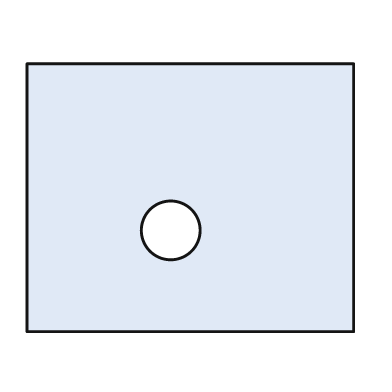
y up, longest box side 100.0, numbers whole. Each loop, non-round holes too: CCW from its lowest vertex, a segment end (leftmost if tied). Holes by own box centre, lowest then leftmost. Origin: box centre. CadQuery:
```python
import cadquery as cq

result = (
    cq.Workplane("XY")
    .moveTo(-50.0, -41.0)
    .lineTo(50.0, -41.0)
    .lineTo(50.0, 41.0)
    .lineTo(-50.0, 41.0)
    .close()
    .moveTo(-6.0, -10.0)
    .circle(9.0)
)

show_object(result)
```